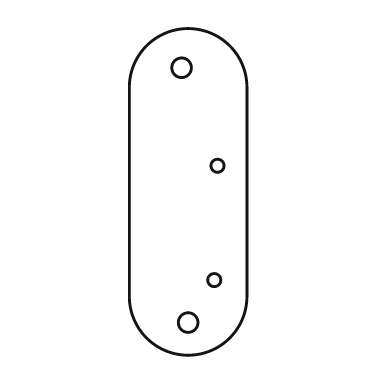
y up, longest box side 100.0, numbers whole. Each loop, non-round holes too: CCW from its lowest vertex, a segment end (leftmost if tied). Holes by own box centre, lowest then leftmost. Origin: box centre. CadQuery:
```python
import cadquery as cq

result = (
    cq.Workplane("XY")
    .moveTo(-18.0, -32.0)
    .threePointArc((0.0, -50.0), (18.0, -32.0))
    .lineTo(18.0, 32.0)
    .threePointArc((0.0, 50.0), (-18.0, 32.0))
    .close()
    .moveTo(0.0, -40.0)
    .circle(3.0)
    .moveTo(8.0, -27.0)
    .circle(2.0)
    .moveTo(9.0, 8.0)
    .circle(2.0)
    .moveTo(-2.0, 38.0)
    .circle(3.0)
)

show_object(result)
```